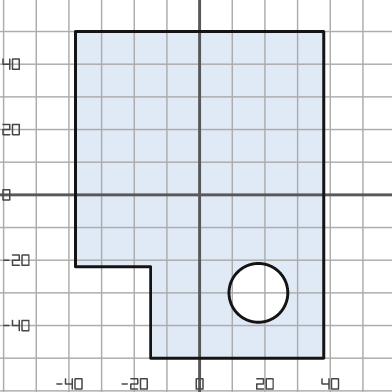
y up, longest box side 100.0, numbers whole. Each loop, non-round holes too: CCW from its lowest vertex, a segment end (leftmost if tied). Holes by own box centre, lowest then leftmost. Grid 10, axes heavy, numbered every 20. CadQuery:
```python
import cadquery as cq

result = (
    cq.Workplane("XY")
    .moveTo(-15.0, -50.0)
    .lineTo(38.0, -50.0)
    .lineTo(38.0, 50.0)
    .lineTo(-38.0, 50.0)
    .lineTo(-38.0, -22.0)
    .lineTo(-15.0, -22.0)
    .close()
    .moveTo(18.0, -30.0)
    .circle(9.0)
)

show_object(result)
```